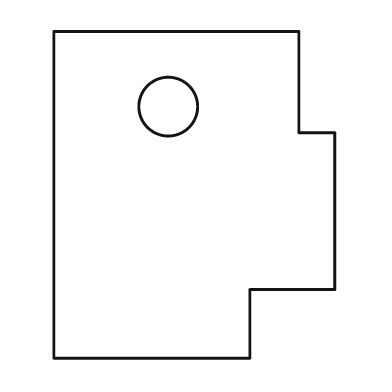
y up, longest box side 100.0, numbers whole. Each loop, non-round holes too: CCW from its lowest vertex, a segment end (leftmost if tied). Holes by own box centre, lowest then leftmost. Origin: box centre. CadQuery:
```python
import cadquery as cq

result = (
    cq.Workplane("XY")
    .moveTo(-43.0, -50.0)
    .lineTo(17.0, -50.0)
    .lineTo(17.0, -29.0)
    .lineTo(43.0, -29.0)
    .lineTo(43.0, 19.0)
    .lineTo(32.0, 19.0)
    .lineTo(32.0, 50.0)
    .lineTo(-43.0, 50.0)
    .close()
    .moveTo(-8.0, 27.0)
    .circle(9.0)
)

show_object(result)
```